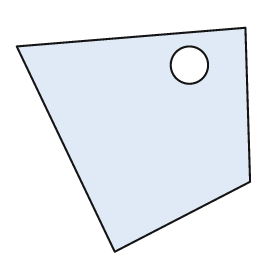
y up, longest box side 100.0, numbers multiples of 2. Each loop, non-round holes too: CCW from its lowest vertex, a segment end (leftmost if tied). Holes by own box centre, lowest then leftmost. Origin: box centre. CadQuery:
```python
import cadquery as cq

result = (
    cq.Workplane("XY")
    .moveTo(-8.0, -48.0)
    .lineTo(50.0, -18.0)
    .lineTo(48.0, 48.0)
    .lineTo(-50.0, 40.0)
    .close()
    .moveTo(24.0, 32.0)
    .circle(8.0)
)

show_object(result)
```